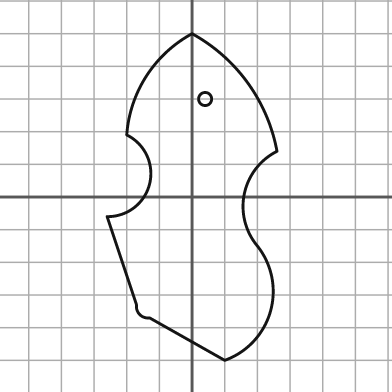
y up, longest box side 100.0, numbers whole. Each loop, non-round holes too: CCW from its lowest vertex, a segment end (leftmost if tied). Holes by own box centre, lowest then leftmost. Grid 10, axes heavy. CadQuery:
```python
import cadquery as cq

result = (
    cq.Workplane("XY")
    .moveTo(10.0, -50.0)
    .threePointArc((24.0, -35.0), (20.0, -15.0))
    .threePointArc((16.0, 1.0), (26.0, 14.0))
    .threePointArc((17.0, 35.0), (0.0, 50.0))
    .threePointArc((-14.0, 37.0), (-20.0, 19.0))
    .threePointArc((-13.0, 4.0), (-26.0, -6.0))
    .lineTo(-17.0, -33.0)
    .threePointArc((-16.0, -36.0), (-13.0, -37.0))
    .close()
    .moveTo(4.0, 30.0)
    .circle(2.0)
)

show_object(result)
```